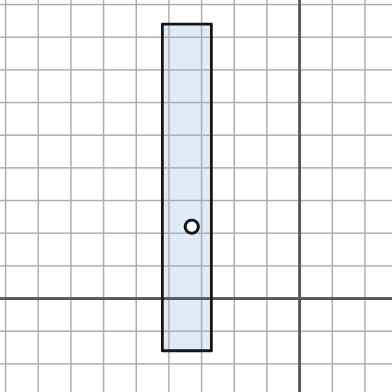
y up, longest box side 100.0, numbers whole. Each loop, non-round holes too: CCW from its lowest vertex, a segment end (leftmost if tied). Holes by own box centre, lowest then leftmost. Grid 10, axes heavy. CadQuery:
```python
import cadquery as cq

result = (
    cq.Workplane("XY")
    .moveTo(-42.0, -16.0)
    .lineTo(-27.0, -16.0)
    .lineTo(-27.0, 84.0)
    .lineTo(-42.0, 84.0)
    .close()
    .moveTo(-33.0, 22.0)
    .circle(2.0)
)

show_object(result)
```